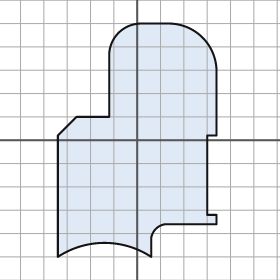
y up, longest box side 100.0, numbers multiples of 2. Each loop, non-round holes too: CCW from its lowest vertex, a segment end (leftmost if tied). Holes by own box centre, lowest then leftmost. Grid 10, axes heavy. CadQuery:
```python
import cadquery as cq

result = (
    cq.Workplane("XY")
    .moveTo(-34.0, -50.0)
    .threePointArc((-14.0, -44.0), (6.0, -50.0))
    .lineTo(6.0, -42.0)
    .threePointArc((8.0, -38.0), (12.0, -36.0))
    .lineTo(34.0, -36.0)
    .lineTo(34.0, -32.0)
    .lineTo(30.0, -32.0)
    .lineTo(30.0, 2.0)
    .lineTo(34.0, 2.0)
    .lineTo(34.0, 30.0)
    .threePointArc((28.0, 44.0), (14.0, 50.0))
    .lineTo(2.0, 50.0)
    .threePointArc((-8.0, 46.0), (-12.0, 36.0))
    .lineTo(-12.0, 10.0)
    .lineTo(-26.0, 10.0)
    .lineTo(-34.0, 2.0)
    .close()
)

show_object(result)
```